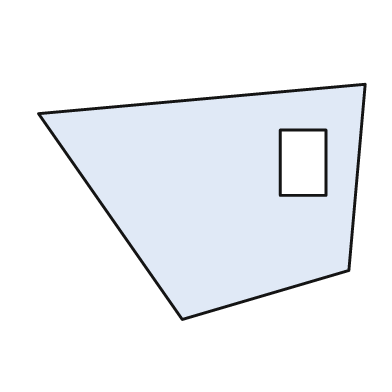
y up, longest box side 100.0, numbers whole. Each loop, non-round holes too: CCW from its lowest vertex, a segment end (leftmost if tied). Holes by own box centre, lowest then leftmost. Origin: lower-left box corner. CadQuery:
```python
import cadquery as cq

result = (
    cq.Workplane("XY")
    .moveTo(44.0, 0.0)
    .lineTo(95.0, 15.0)
    .lineTo(100.0, 72.0)
    .lineTo(0.0, 63.0)
    .close()
    .moveTo(74.0, 38.0)
    .lineTo(88.0, 38.0)
    .lineTo(88.0, 58.0)
    .lineTo(74.0, 58.0)
    .close()
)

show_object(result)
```